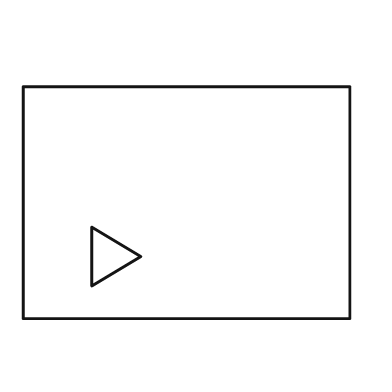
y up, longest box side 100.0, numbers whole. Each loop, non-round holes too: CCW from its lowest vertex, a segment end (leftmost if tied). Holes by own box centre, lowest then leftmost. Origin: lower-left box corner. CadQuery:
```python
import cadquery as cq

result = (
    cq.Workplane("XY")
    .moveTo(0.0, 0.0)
    .lineTo(100.0, 0.0)
    .lineTo(100.0, 71.0)
    .lineTo(0.0, 71.0)
    .close()
    .moveTo(21.0, 10.0)
    .lineTo(36.0, 19.0)
    .lineTo(21.0, 28.0)
    .close()
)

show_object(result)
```